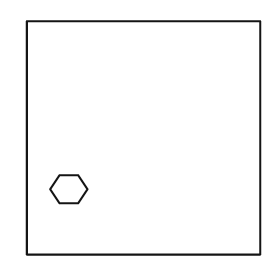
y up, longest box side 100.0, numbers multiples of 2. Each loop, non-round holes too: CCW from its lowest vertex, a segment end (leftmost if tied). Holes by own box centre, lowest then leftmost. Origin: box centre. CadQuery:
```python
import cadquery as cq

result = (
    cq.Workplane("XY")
    .moveTo(-50.0, -50.0)
    .lineTo(50.0, -50.0)
    .lineTo(50.0, 50.0)
    .lineTo(-50.0, 50.0)
    .close()
    .moveTo(-36.0, -28.0)
    .lineTo(-28.0, -28.0)
    .lineTo(-24.0, -22.0)
    .lineTo(-28.0, -16.0)
    .lineTo(-36.0, -16.0)
    .lineTo(-40.0, -22.0)
    .close()
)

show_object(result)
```